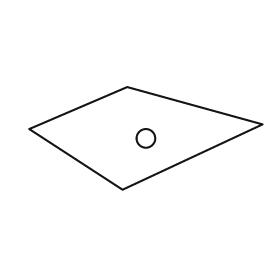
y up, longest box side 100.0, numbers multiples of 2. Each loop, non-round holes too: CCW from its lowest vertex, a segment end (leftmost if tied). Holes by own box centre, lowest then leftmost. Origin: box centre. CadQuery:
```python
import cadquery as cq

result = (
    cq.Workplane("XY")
    .moveTo(-10.0, -22.0)
    .lineTo(50.0, 6.0)
    .lineTo(-8.0, 22.0)
    .lineTo(-50.0, 4.0)
    .close()
    .moveTo(0.0, 0.0)
    .circle(4.0)
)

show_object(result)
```